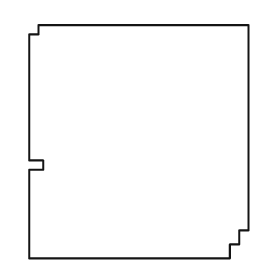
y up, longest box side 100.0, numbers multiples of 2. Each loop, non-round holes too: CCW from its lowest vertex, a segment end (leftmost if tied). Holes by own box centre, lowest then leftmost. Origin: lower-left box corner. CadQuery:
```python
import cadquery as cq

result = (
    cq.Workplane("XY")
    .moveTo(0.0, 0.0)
    .lineTo(86.0, 0.0)
    .lineTo(86.0, 6.0)
    .lineTo(90.0, 6.0)
    .lineTo(90.0, 12.0)
    .lineTo(94.0, 12.0)
    .lineTo(94.0, 100.0)
    .lineTo(4.0, 100.0)
    .lineTo(4.0, 96.0)
    .lineTo(0.0, 96.0)
    .lineTo(0.0, 42.0)
    .lineTo(6.0, 42.0)
    .lineTo(6.0, 38.0)
    .lineTo(0.0, 38.0)
    .close()
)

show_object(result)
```